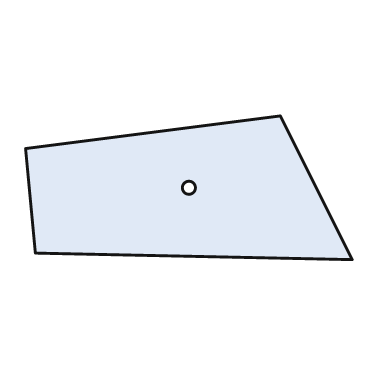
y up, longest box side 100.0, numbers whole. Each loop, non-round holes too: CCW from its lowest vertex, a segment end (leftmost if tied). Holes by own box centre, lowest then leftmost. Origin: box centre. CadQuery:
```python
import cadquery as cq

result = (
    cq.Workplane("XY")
    .moveTo(50.0, -22.0)
    .lineTo(28.0, 22.0)
    .lineTo(-50.0, 12.0)
    .lineTo(-47.0, -20.0)
    .close()
    .moveTo(0.0, 0.0)
    .circle(2.0)
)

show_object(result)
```